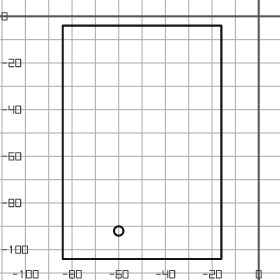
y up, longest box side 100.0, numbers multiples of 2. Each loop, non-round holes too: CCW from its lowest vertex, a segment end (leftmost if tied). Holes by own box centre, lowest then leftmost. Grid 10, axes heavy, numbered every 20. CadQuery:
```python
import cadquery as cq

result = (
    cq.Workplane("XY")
    .moveTo(-84.0, -104.0)
    .lineTo(-16.0, -104.0)
    .lineTo(-16.0, -4.0)
    .lineTo(-84.0, -4.0)
    .close()
    .moveTo(-60.0, -92.0)
    .circle(2.0)
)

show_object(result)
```